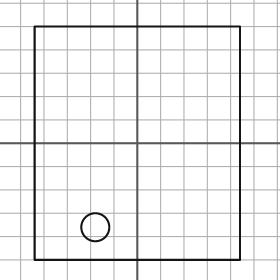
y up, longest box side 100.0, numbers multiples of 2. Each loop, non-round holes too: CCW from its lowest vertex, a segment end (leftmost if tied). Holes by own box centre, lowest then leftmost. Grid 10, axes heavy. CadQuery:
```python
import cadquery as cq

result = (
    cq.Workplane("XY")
    .moveTo(-44.0, -50.0)
    .lineTo(44.0, -50.0)
    .lineTo(44.0, 50.0)
    .lineTo(-44.0, 50.0)
    .close()
    .moveTo(-18.0, -36.0)
    .circle(6.0)
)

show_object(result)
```